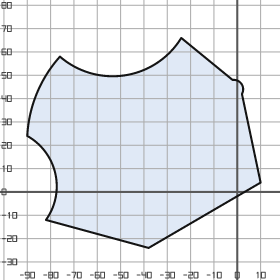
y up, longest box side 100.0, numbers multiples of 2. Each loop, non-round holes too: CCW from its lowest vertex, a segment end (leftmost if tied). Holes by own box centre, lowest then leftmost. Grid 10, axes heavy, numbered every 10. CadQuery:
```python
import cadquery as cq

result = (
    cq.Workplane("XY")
    .moveTo(-38.0, -24.0)
    .lineTo(10.0, 4.0)
    .lineTo(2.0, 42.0)
    .threePointArc((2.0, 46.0), (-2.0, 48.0))
    .lineTo(-24.0, 66.0)
    .threePointArc((-48.0, 50.0), (-76.0, 58.0))
    .threePointArc((-86.0, 42.0), (-90.0, 24.0))
    .threePointArc((-78.0, 8.0), (-82.0, -12.0))
    .close()
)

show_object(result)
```